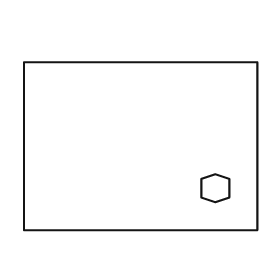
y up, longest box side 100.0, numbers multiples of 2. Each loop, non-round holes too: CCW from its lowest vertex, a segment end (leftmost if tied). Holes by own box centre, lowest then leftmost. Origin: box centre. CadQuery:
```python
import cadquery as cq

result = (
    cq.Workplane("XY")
    .moveTo(-50.0, -36.0)
    .lineTo(50.0, -36.0)
    .lineTo(50.0, 36.0)
    .lineTo(-50.0, 36.0)
    .close()
    .moveTo(32.0, -24.0)
    .lineTo(38.0, -22.0)
    .lineTo(38.0, -14.0)
    .lineTo(32.0, -12.0)
    .lineTo(26.0, -14.0)
    .lineTo(26.0, -22.0)
    .close()
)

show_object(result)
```